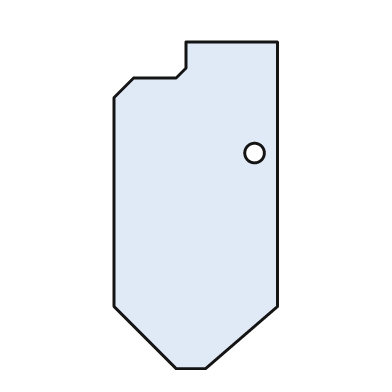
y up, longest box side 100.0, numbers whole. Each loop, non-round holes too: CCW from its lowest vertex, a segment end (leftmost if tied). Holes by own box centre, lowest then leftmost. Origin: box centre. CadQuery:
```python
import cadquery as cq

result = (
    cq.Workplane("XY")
    .moveTo(-6.0, -50.0)
    .lineTo(3.0, -50.0)
    .lineTo(25.0, -31.0)
    .lineTo(25.0, 50.0)
    .lineTo(-3.0, 50.0)
    .lineTo(-3.0, 42.0)
    .lineTo(-6.0, 39.0)
    .lineTo(-19.0, 39.0)
    .lineTo(-25.0, 33.0)
    .lineTo(-25.0, -31.0)
    .close()
    .moveTo(18.0, 16.0)
    .circle(3.0)
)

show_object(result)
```